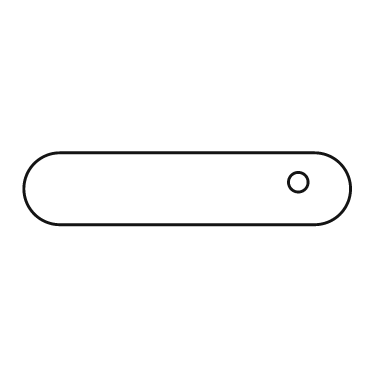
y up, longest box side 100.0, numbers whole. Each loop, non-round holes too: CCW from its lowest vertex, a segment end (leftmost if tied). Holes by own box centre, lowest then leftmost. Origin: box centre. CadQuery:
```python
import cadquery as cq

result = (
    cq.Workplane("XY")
    .moveTo(-39.0, -11.0)
    .lineTo(39.0, -11.0)
    .threePointArc((50.0, 0.0), (39.0, 11.0))
    .lineTo(-39.0, 11.0)
    .threePointArc((-50.0, 0.0), (-39.0, -11.0))
    .close()
    .moveTo(34.0, 2.0)
    .circle(3.0)
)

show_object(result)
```